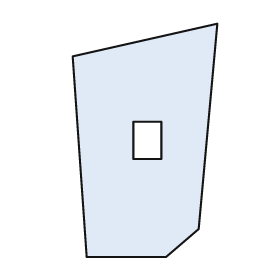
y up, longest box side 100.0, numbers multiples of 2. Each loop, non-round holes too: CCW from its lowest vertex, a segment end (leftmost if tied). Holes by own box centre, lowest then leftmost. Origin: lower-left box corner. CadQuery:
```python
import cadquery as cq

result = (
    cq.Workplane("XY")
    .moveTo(6.0, 0.0)
    .lineTo(40.0, 0.0)
    .lineTo(54.0, 12.0)
    .lineTo(62.0, 100.0)
    .lineTo(0.0, 86.0)
    .close()
    .moveTo(26.0, 42.0)
    .lineTo(38.0, 42.0)
    .lineTo(38.0, 58.0)
    .lineTo(26.0, 58.0)
    .close()
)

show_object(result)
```